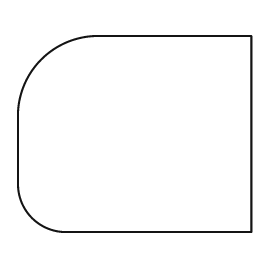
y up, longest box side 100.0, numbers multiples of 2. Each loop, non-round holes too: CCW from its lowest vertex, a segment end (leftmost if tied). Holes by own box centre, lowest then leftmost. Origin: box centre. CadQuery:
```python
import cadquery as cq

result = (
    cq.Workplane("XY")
    .moveTo(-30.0, -42.0)
    .lineTo(50.0, -42.0)
    .lineTo(50.0, 42.0)
    .lineTo(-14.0, 42.0)
    .threePointArc((-40.0, 32.0), (-50.0, 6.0))
    .lineTo(-50.0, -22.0)
    .threePointArc((-44.0, -36.0), (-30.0, -42.0))
    .close()
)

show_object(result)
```